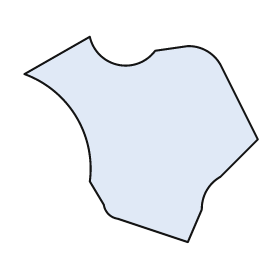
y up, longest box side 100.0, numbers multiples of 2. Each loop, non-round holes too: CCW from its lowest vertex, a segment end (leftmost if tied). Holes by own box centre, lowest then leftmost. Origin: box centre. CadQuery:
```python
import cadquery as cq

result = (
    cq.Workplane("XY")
    .moveTo(20.0, -44.0)
    .lineTo(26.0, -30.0)
    .threePointArc((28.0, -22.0), (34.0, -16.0))
    .lineTo(50.0, 0.0)
    .lineTo(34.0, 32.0)
    .threePointArc((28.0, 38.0), (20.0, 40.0))
    .lineTo(6.0, 38.0)
    .threePointArc((-10.0, 32.0), (-22.0, 44.0))
    .lineTo(-50.0, 28.0)
    .threePointArc((-28.0, 10.0), (-22.0, -18.0))
    .lineTo(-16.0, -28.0)
    .threePointArc((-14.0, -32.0), (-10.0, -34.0))
    .close()
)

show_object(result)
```